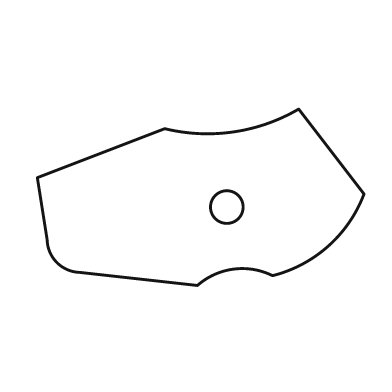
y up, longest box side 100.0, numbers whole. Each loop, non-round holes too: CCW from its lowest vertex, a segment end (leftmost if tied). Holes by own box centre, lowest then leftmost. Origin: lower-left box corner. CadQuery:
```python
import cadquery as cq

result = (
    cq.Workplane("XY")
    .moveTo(49.0, 0.0)
    .threePointArc((60.0, 5.0), (72.0, 3.0))
    .threePointArc((89.0, 12.0), (100.0, 28.0))
    .lineTo(80.0, 54.0)
    .threePointArc((60.0, 47.0), (39.0, 48.0))
    .lineTo(0.0, 33.0)
    .lineTo(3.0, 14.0)
    .threePointArc((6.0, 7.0), (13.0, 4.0))
    .close()
    .moveTo(58.0, 24.0)
    .circle(5.0)
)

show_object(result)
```